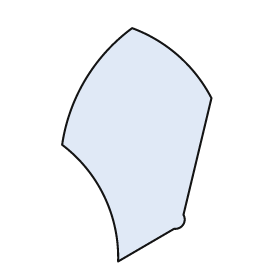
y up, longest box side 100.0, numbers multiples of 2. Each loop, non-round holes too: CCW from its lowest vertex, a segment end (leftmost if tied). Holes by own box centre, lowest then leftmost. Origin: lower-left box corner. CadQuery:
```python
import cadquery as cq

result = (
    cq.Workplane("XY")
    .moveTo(24.0, 0.0)
    .lineTo(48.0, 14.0)
    .threePointArc((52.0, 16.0), (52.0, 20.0))
    .lineTo(64.0, 70.0)
    .threePointArc((50.0, 88.0), (30.0, 100.0))
    .threePointArc((10.0, 78.0), (0.0, 50.0))
    .threePointArc((18.0, 28.0), (24.0, 0.0))
    .close()
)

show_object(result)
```